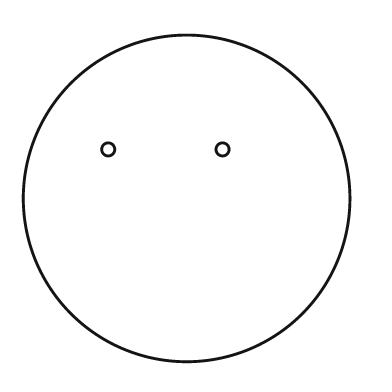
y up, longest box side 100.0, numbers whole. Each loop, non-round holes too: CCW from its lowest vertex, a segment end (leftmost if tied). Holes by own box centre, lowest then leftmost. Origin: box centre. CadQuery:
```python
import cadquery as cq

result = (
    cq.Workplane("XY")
    .moveTo(0.0, 0.0)
    .circle(50.0)
    .moveTo(-24.0, 15.0)
    .circle(2.0)
    .moveTo(11.0, 15.0)
    .circle(2.0)
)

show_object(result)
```